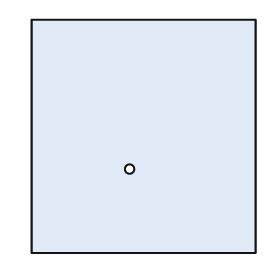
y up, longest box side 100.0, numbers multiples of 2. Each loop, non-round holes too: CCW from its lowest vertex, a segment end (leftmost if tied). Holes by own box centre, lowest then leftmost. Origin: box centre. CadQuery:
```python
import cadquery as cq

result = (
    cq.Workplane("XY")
    .moveTo(-48.0, -50.0)
    .lineTo(48.0, -50.0)
    .lineTo(48.0, 50.0)
    .lineTo(-48.0, 50.0)
    .close()
    .moveTo(-6.0, -14.0)
    .circle(2.0)
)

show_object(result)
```